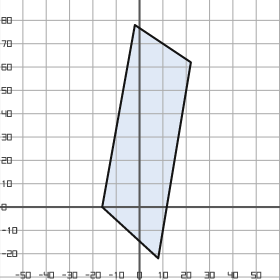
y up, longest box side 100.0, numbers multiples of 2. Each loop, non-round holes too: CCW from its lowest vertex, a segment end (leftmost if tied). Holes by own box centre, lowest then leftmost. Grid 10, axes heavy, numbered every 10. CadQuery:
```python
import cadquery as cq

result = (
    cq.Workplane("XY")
    .moveTo(8.0, -22.0)
    .lineTo(22.0, 62.0)
    .lineTo(-2.0, 78.0)
    .lineTo(-16.0, 0.0)
    .close()
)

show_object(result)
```